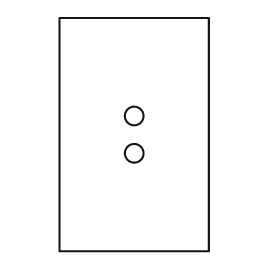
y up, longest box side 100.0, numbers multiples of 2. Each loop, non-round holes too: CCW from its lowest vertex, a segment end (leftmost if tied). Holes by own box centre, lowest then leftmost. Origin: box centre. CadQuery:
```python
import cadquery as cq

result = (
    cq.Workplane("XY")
    .moveTo(-32.0, -50.0)
    .lineTo(32.0, -50.0)
    .lineTo(32.0, 50.0)
    .lineTo(-32.0, 50.0)
    .close()
    .moveTo(0.0, -8.0)
    .circle(4.0)
    .moveTo(0.0, 8.0)
    .circle(4.0)
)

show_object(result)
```